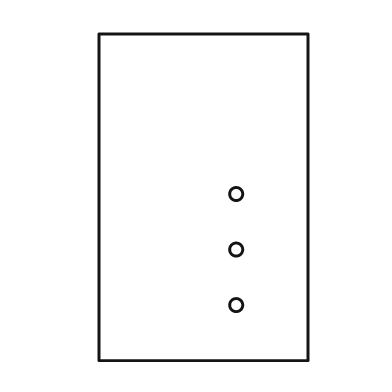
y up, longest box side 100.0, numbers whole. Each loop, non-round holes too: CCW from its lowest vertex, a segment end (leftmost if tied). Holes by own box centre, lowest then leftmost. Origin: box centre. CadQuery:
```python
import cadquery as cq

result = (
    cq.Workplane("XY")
    .moveTo(-32.0, -50.0)
    .lineTo(32.0, -50.0)
    .lineTo(32.0, 50.0)
    .lineTo(-32.0, 50.0)
    .close()
    .moveTo(10.0, -33.0)
    .circle(2.0)
    .moveTo(10.0, -16.0)
    .circle(2.0)
    .moveTo(10.0, 1.0)
    .circle(2.0)
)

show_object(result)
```